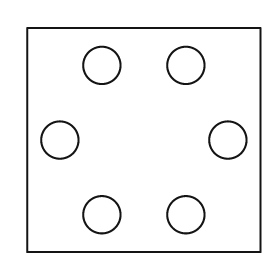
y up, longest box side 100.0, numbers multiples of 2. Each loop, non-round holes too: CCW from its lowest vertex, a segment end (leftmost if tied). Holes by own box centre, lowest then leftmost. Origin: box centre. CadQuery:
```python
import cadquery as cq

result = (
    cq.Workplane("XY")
    .moveTo(-50.0, -48.0)
    .lineTo(50.0, -48.0)
    .lineTo(50.0, 48.0)
    .lineTo(-50.0, 48.0)
    .close()
    .moveTo(-18.0, -32.0)
    .circle(8.0)
    .moveTo(18.0, -32.0)
    .circle(8.0)
    .moveTo(-36.0, 0.0)
    .circle(8.0)
    .moveTo(36.0, 0.0)
    .circle(8.0)
    .moveTo(-18.0, 32.0)
    .circle(8.0)
    .moveTo(18.0, 32.0)
    .circle(8.0)
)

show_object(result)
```